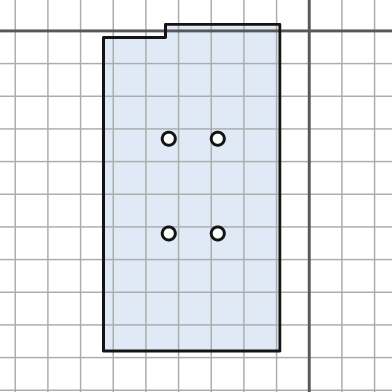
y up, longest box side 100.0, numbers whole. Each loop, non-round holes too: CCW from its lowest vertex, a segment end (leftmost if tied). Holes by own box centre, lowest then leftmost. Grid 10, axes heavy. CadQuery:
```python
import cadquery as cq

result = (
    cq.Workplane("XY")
    .moveTo(-63.0, -98.0)
    .lineTo(-9.0, -98.0)
    .lineTo(-9.0, 2.0)
    .lineTo(-44.0, 2.0)
    .lineTo(-44.0, -2.0)
    .lineTo(-63.0, -2.0)
    .close()
    .moveTo(-43.0, -62.0)
    .circle(2.0)
    .moveTo(-28.0, -62.0)
    .circle(2.0)
    .moveTo(-43.0, -33.0)
    .circle(2.0)
    .moveTo(-28.0, -33.0)
    .circle(2.0)
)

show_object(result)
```